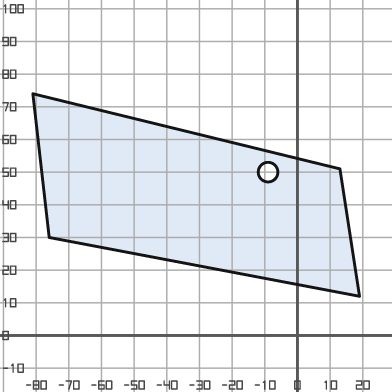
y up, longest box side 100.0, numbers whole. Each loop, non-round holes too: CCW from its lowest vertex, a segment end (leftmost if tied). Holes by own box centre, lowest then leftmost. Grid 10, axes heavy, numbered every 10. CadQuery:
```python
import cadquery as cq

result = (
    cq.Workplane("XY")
    .moveTo(19.0, 12.0)
    .lineTo(13.0, 51.0)
    .lineTo(-81.0, 74.0)
    .lineTo(-76.0, 30.0)
    .close()
    .moveTo(-9.0, 50.0)
    .circle(3.0)
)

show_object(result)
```